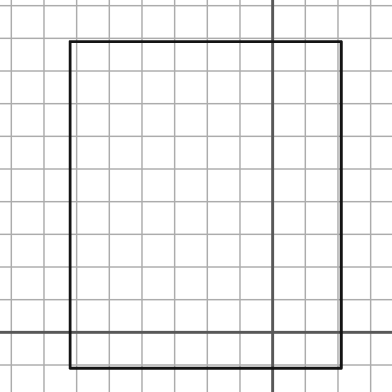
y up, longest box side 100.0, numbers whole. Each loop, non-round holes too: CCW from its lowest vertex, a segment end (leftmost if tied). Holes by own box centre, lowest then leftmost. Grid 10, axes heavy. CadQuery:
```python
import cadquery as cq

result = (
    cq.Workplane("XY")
    .moveTo(-62.0, -11.0)
    .lineTo(21.0, -11.0)
    .lineTo(21.0, 89.0)
    .lineTo(-62.0, 89.0)
    .close()
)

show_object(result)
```